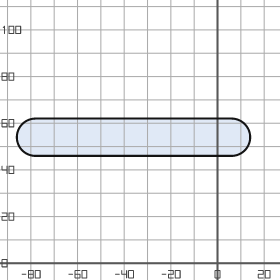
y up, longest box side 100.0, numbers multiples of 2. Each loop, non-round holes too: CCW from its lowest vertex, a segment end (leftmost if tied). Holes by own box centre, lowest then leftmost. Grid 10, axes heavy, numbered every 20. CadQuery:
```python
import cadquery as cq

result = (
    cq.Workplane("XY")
    .moveTo(-78.0, 46.0)
    .lineTo(6.0, 46.0)
    .threePointArc((14.0, 54.0), (6.0, 62.0))
    .lineTo(-78.0, 62.0)
    .threePointArc((-86.0, 54.0), (-78.0, 46.0))
    .close()
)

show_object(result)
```